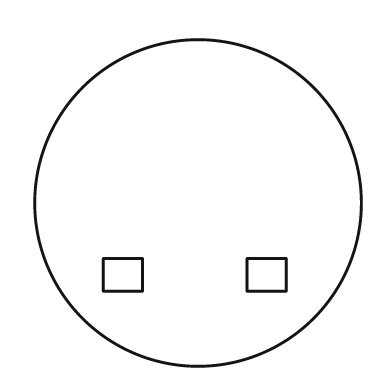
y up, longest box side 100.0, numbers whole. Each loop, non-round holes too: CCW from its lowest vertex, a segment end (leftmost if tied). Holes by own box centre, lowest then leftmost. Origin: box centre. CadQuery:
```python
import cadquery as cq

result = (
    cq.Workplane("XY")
    .moveTo(0.0, 0.0)
    .circle(50.0)
    .moveTo(-29.0, -27.0)
    .lineTo(-17.0, -27.0)
    .lineTo(-17.0, -17.0)
    .lineTo(-29.0, -17.0)
    .close()
    .moveTo(15.0, -27.0)
    .lineTo(27.0, -27.0)
    .lineTo(27.0, -17.0)
    .lineTo(15.0, -17.0)
    .close()
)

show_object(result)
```